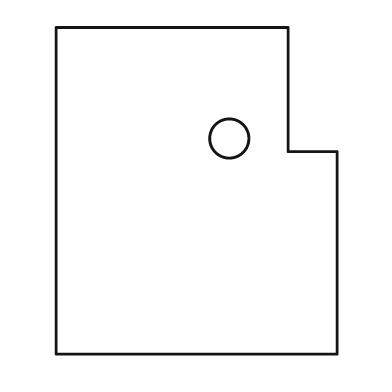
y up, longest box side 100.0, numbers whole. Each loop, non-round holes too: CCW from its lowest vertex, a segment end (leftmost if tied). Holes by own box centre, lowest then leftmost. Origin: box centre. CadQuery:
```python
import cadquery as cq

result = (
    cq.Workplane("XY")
    .moveTo(-43.0, -50.0)
    .lineTo(43.0, -50.0)
    .lineTo(43.0, 12.0)
    .lineTo(28.0, 12.0)
    .lineTo(28.0, 50.0)
    .lineTo(-43.0, 50.0)
    .close()
    .moveTo(10.0, 16.0)
    .circle(6.0)
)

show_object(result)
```